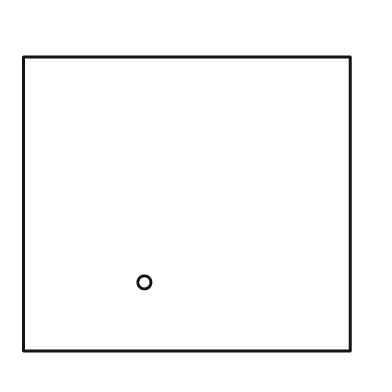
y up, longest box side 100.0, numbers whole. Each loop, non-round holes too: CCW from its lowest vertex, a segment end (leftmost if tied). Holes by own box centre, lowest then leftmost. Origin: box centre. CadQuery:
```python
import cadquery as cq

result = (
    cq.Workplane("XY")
    .moveTo(-50.0, -45.0)
    .lineTo(50.0, -45.0)
    .lineTo(50.0, 45.0)
    .lineTo(-50.0, 45.0)
    .close()
    .moveTo(-13.0, -24.0)
    .circle(2.0)
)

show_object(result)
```